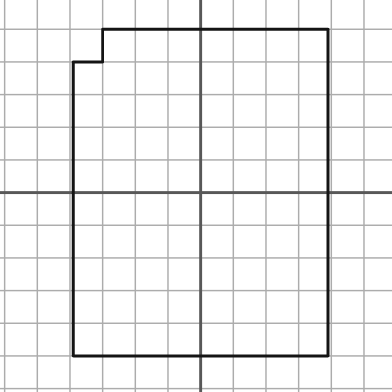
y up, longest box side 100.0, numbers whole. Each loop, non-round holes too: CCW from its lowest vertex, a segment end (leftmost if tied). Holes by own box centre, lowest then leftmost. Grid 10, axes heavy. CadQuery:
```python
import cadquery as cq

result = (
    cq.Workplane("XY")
    .moveTo(-39.0, -50.0)
    .lineTo(39.0, -50.0)
    .lineTo(39.0, 50.0)
    .lineTo(-30.0, 50.0)
    .lineTo(-30.0, 40.0)
    .lineTo(-39.0, 40.0)
    .close()
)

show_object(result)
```